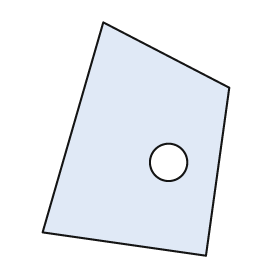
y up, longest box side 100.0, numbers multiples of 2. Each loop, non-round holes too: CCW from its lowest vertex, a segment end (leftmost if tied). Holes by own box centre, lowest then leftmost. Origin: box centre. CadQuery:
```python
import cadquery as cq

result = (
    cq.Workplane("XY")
    .moveTo(30.0, -50.0)
    .lineTo(40.0, 22.0)
    .lineTo(-14.0, 50.0)
    .lineTo(-40.0, -40.0)
    .close()
    .moveTo(14.0, -10.0)
    .circle(8.0)
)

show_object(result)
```